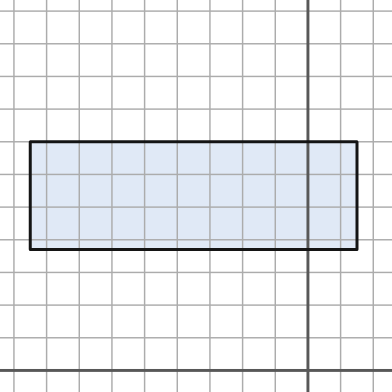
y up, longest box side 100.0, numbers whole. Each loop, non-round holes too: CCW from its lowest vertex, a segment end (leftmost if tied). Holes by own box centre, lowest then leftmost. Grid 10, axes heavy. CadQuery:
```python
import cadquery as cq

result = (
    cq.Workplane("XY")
    .moveTo(-85.0, 37.0)
    .lineTo(15.0, 37.0)
    .lineTo(15.0, 70.0)
    .lineTo(-85.0, 70.0)
    .close()
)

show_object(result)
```